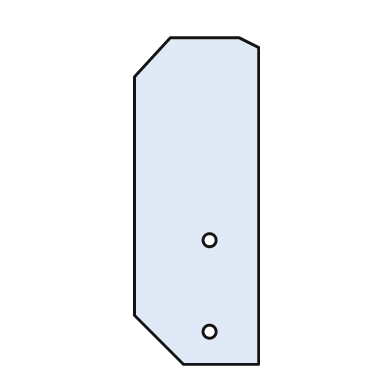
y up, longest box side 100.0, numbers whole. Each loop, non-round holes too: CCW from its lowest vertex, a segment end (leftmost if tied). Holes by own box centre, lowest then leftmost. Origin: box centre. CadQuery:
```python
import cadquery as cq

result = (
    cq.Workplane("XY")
    .moveTo(-4.0, -50.0)
    .lineTo(19.0, -50.0)
    .lineTo(19.0, 47.0)
    .lineTo(13.0, 50.0)
    .lineTo(-8.0, 50.0)
    .lineTo(-19.0, 38.0)
    .lineTo(-19.0, -35.0)
    .close()
    .moveTo(4.0, -40.0)
    .circle(2.0)
    .moveTo(4.0, -12.0)
    .circle(2.0)
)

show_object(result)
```